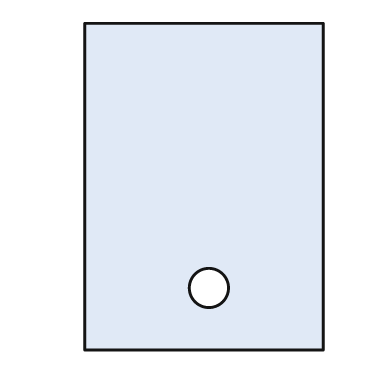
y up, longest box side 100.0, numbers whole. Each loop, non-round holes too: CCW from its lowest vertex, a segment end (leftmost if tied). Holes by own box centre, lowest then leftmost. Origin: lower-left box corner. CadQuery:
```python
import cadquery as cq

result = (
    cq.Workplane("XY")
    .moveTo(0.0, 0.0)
    .lineTo(73.0, 0.0)
    .lineTo(73.0, 100.0)
    .lineTo(0.0, 100.0)
    .close()
    .moveTo(38.0, 19.0)
    .circle(6.0)
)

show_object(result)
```